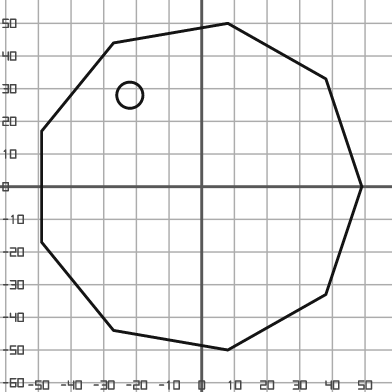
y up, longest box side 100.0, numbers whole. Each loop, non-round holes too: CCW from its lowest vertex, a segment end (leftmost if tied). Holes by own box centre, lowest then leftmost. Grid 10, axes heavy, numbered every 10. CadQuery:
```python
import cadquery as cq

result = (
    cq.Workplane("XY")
    .moveTo(8.0, -50.0)
    .lineTo(38.0, -33.0)
    .lineTo(49.0, 0.0)
    .lineTo(38.0, 33.0)
    .lineTo(8.0, 50.0)
    .lineTo(-27.0, 44.0)
    .lineTo(-49.0, 17.0)
    .lineTo(-49.0, -17.0)
    .lineTo(-27.0, -44.0)
    .close()
    .moveTo(-22.0, 28.0)
    .circle(4.0)
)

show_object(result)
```